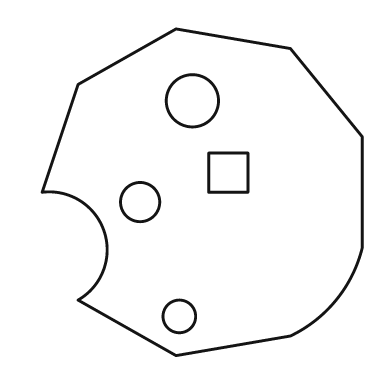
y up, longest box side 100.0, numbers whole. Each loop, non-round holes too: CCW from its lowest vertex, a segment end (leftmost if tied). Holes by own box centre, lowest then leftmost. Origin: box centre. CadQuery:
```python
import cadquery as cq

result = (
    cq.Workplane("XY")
    .moveTo(-8.0, -50.0)
    .lineTo(27.0, -44.0)
    .threePointArc((41.0, -33.0), (49.0, -17.0))
    .lineTo(49.0, 17.0)
    .lineTo(27.0, 44.0)
    .lineTo(-8.0, 50.0)
    .lineTo(-38.0, 33.0)
    .lineTo(-49.0, 0.0)
    .threePointArc((-30.0, -12.0), (-38.0, -33.0))
    .close()
    .moveTo(-7.0, -38.0)
    .circle(5.0)
    .moveTo(-19.0, -3.0)
    .circle(6.0)
    .moveTo(2.0, 0.0)
    .lineTo(14.0, 0.0)
    .lineTo(14.0, 12.0)
    .lineTo(2.0, 12.0)
    .close()
    .moveTo(-3.0, 28.0)
    .circle(8.0)
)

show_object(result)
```